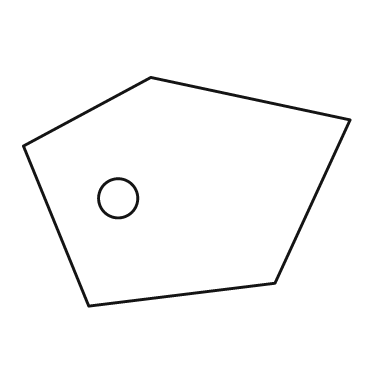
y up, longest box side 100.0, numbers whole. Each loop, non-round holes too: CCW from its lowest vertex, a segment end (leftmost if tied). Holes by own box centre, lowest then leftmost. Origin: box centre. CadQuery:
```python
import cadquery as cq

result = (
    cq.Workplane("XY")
    .moveTo(-30.0, -35.0)
    .lineTo(27.0, -28.0)
    .lineTo(50.0, 22.0)
    .lineTo(-11.0, 35.0)
    .lineTo(-50.0, 14.0)
    .close()
    .moveTo(-21.0, -2.0)
    .circle(6.0)
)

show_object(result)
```